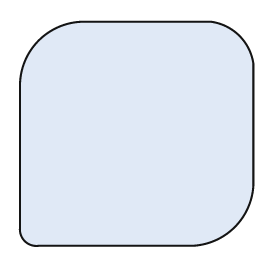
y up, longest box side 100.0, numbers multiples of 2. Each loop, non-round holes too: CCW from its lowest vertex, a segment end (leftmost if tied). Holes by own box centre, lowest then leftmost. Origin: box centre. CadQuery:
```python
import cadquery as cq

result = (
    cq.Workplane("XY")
    .moveTo(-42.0, -48.0)
    .lineTo(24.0, -48.0)
    .threePointArc((42.0, -40.0), (50.0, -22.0))
    .lineTo(50.0, 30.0)
    .threePointArc((44.0, 42.0), (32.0, 48.0))
    .lineTo(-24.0, 48.0)
    .threePointArc((-42.0, 40.0), (-50.0, 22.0))
    .lineTo(-50.0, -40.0)
    .threePointArc((-48.0, -46.0), (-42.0, -48.0))
    .close()
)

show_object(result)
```